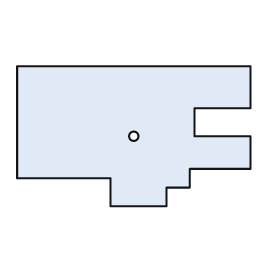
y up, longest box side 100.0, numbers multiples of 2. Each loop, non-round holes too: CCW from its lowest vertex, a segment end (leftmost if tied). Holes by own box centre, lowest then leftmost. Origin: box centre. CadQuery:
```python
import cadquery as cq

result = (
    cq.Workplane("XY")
    .moveTo(-10.0, -30.0)
    .lineTo(14.0, -30.0)
    .lineTo(14.0, -22.0)
    .lineTo(24.0, -22.0)
    .lineTo(24.0, -14.0)
    .lineTo(50.0, -14.0)
    .lineTo(50.0, 0.0)
    .lineTo(26.0, 0.0)
    .lineTo(26.0, 12.0)
    .lineTo(50.0, 12.0)
    .lineTo(50.0, 30.0)
    .lineTo(-50.0, 30.0)
    .lineTo(-50.0, -18.0)
    .lineTo(-10.0, -18.0)
    .close()
    .moveTo(0.0, 0.0)
    .circle(2.0)
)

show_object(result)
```